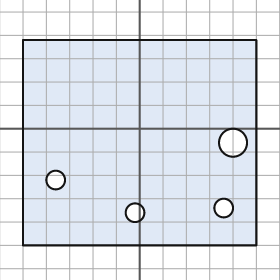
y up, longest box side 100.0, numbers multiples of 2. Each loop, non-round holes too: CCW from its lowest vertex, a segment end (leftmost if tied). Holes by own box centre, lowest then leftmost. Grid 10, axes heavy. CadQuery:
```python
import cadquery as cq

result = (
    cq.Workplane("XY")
    .moveTo(-50.0, -50.0)
    .lineTo(50.0, -50.0)
    .lineTo(50.0, 38.0)
    .lineTo(-50.0, 38.0)
    .close()
    .moveTo(-2.0, -36.0)
    .circle(4.0)
    .moveTo(36.0, -34.0)
    .circle(4.0)
    .moveTo(-36.0, -22.0)
    .circle(4.0)
    .moveTo(40.0, -6.0)
    .circle(6.0)
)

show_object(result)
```